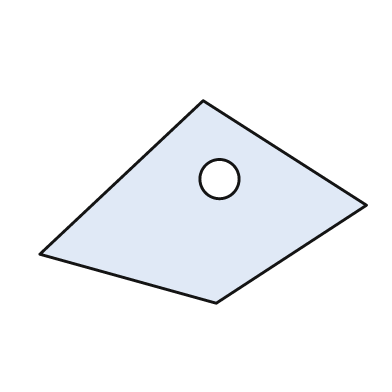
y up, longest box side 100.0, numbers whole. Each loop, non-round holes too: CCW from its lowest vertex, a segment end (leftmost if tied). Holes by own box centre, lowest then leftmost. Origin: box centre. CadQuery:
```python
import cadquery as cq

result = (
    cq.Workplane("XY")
    .moveTo(4.0, -31.0)
    .lineTo(50.0, -1.0)
    .lineTo(0.0, 31.0)
    .lineTo(-50.0, -16.0)
    .close()
    .moveTo(5.0, 7.0)
    .circle(6.0)
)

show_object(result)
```